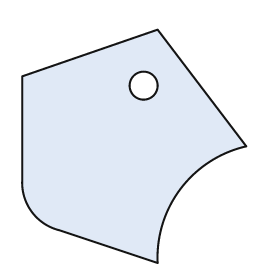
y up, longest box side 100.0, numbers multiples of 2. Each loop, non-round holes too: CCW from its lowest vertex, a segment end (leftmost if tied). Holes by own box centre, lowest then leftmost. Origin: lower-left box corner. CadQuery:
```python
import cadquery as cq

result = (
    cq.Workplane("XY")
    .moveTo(58.0, 0.0)
    .threePointArc((68.0, 32.0), (96.0, 50.0))
    .lineTo(58.0, 100.0)
    .lineTo(0.0, 80.0)
    .lineTo(0.0, 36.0)
    .threePointArc((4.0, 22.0), (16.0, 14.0))
    .close()
    .moveTo(52.0, 76.0)
    .circle(6.0)
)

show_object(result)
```